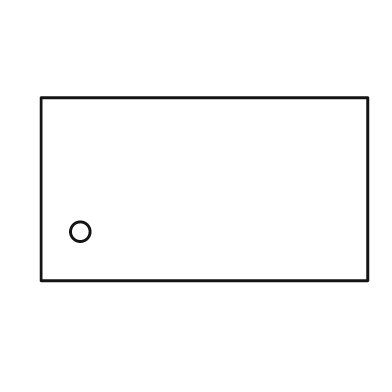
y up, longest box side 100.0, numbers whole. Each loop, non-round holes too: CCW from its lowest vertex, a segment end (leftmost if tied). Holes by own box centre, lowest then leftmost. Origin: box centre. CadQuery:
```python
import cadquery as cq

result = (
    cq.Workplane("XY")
    .moveTo(-50.0, -28.0)
    .lineTo(50.0, -28.0)
    .lineTo(50.0, 28.0)
    .lineTo(-50.0, 28.0)
    .close()
    .moveTo(-38.0, -13.0)
    .circle(3.0)
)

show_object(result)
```